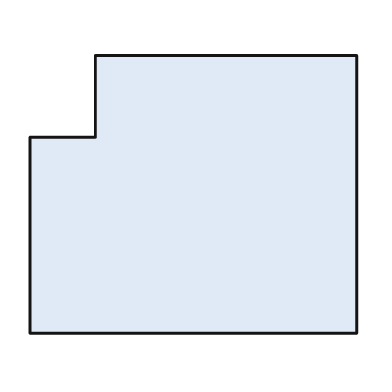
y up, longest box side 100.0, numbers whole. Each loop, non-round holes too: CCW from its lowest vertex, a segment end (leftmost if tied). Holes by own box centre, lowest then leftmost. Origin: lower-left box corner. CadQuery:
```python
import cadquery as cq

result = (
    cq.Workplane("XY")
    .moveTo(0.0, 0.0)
    .lineTo(100.0, 0.0)
    .lineTo(100.0, 85.0)
    .lineTo(20.0, 85.0)
    .lineTo(20.0, 60.0)
    .lineTo(0.0, 60.0)
    .close()
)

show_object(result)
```